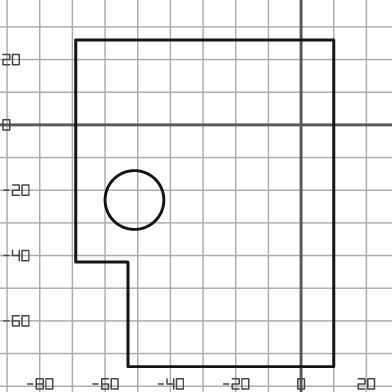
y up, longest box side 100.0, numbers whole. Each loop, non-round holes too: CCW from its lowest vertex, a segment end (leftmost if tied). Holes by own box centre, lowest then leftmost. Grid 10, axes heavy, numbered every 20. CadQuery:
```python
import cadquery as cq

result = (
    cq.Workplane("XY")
    .moveTo(-53.0, -74.0)
    .lineTo(10.0, -74.0)
    .lineTo(10.0, 26.0)
    .lineTo(-69.0, 26.0)
    .lineTo(-69.0, -42.0)
    .lineTo(-53.0, -42.0)
    .close()
    .moveTo(-51.0, -23.0)
    .circle(9.0)
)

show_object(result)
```